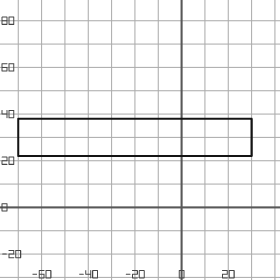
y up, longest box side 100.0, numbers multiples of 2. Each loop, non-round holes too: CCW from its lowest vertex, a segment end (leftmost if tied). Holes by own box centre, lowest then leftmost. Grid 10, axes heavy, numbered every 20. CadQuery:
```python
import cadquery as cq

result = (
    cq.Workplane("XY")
    .moveTo(-70.0, 22.0)
    .lineTo(30.0, 22.0)
    .lineTo(30.0, 38.0)
    .lineTo(-70.0, 38.0)
    .close()
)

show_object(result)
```